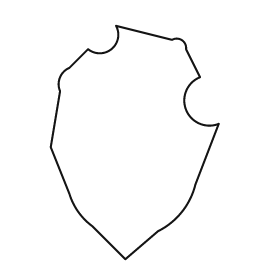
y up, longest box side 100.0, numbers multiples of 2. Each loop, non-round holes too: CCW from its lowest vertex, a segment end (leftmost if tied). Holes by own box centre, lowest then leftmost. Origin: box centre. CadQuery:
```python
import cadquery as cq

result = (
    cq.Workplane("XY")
    .moveTo(-4.0, -50.0)
    .lineTo(10.0, -38.0)
    .threePointArc((20.0, -30.0), (26.0, -18.0))
    .lineTo(36.0, 8.0)
    .threePointArc((22.0, 14.0), (28.0, 28.0))
    .lineTo(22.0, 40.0)
    .threePointArc((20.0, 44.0), (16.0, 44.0))
    .lineTo(-8.0, 50.0)
    .threePointArc((-10.0, 40.0), (-20.0, 40.0))
    .lineTo(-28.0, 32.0)
    .threePointArc((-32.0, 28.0), (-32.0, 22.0))
    .lineTo(-36.0, -2.0)
    .lineTo(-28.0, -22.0)
    .threePointArc((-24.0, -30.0), (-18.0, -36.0))
    .close()
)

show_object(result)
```